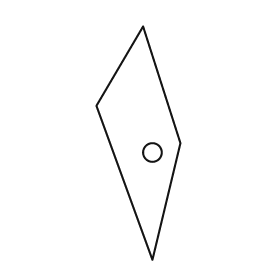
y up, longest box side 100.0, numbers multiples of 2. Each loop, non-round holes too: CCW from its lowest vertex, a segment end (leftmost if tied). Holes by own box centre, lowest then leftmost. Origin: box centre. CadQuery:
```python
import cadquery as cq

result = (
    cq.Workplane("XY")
    .moveTo(6.0, -50.0)
    .lineTo(18.0, 0.0)
    .lineTo(2.0, 50.0)
    .lineTo(-18.0, 16.0)
    .close()
    .moveTo(6.0, -4.0)
    .circle(4.0)
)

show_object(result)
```